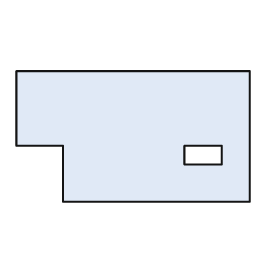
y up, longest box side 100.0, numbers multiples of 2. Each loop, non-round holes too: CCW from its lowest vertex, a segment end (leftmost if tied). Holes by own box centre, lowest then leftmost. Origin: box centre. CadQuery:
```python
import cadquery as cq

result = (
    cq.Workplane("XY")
    .moveTo(-30.0, -28.0)
    .lineTo(50.0, -28.0)
    .lineTo(50.0, 28.0)
    .lineTo(-50.0, 28.0)
    .lineTo(-50.0, -4.0)
    .lineTo(-30.0, -4.0)
    .close()
    .moveTo(22.0, -12.0)
    .lineTo(38.0, -12.0)
    .lineTo(38.0, -4.0)
    .lineTo(22.0, -4.0)
    .close()
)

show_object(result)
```